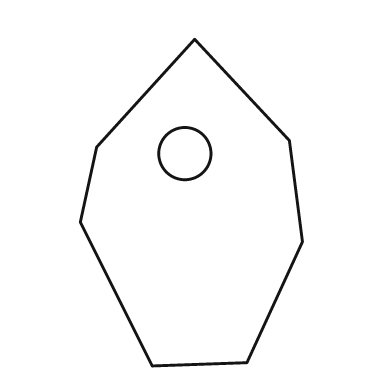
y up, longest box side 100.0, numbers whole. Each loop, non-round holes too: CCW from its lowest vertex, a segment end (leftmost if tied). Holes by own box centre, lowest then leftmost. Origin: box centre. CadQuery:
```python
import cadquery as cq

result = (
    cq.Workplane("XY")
    .moveTo(-12.0, -50.0)
    .lineTo(17.0, -49.0)
    .lineTo(34.0, -12.0)
    .lineTo(30.0, 19.0)
    .lineTo(1.0, 50.0)
    .lineTo(-29.0, 17.0)
    .lineTo(-34.0, -6.0)
    .close()
    .moveTo(-2.0, 15.0)
    .circle(8.0)
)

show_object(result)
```